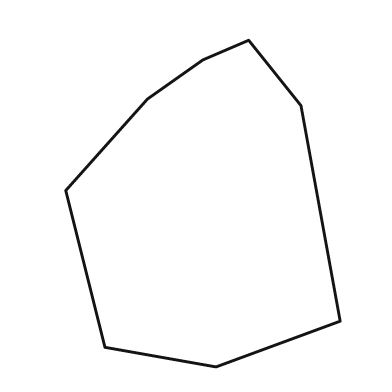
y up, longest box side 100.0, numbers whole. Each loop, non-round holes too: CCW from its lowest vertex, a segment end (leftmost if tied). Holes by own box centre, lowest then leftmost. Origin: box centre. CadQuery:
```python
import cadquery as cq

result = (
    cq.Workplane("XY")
    .moveTo(4.0, -50.0)
    .lineTo(42.0, -36.0)
    .lineTo(30.0, 30.0)
    .lineTo(14.0, 50.0)
    .lineTo(0.0, 44.0)
    .lineTo(-17.0, 32.0)
    .lineTo(-42.0, 4.0)
    .lineTo(-30.0, -44.0)
    .close()
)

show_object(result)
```